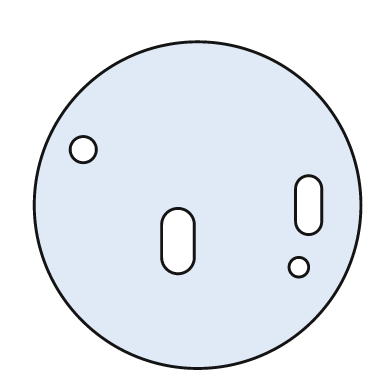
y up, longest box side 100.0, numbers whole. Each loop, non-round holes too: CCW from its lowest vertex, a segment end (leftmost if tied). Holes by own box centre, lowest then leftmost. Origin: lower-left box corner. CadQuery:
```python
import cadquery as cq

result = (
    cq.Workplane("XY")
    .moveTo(50.0, 50.0)
    .circle(50.0)
    .moveTo(81.0, 31.0)
    .circle(3.0)
    .moveTo(39.0, 34.0)
    .threePointArc((44.0, 29.0), (49.0, 34.0))
    .lineTo(49.0, 44.0)
    .threePointArc((44.0, 49.0), (39.0, 44.0))
    .close()
    .moveTo(80.0, 45.0)
    .threePointArc((84.0, 41.0), (88.0, 45.0))
    .lineTo(88.0, 55.0)
    .threePointArc((84.0, 59.0), (80.0, 55.0))
    .close()
    .moveTo(15.0, 67.0)
    .circle(4.0)
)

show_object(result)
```